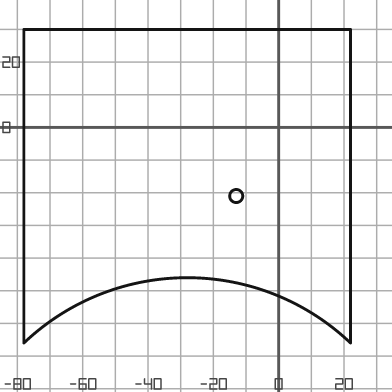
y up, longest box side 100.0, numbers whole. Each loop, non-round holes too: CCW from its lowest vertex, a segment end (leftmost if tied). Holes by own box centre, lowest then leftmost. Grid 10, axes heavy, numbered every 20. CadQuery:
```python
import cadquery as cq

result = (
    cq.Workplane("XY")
    .moveTo(-78.0, -66.0)
    .threePointArc((-28.0, -46.0), (22.0, -66.0))
    .lineTo(22.0, 30.0)
    .lineTo(-78.0, 30.0)
    .close()
    .moveTo(-13.0, -21.0)
    .circle(2.0)
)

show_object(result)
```